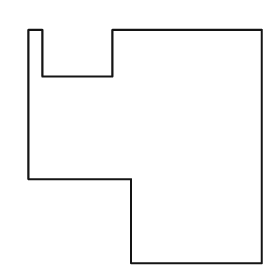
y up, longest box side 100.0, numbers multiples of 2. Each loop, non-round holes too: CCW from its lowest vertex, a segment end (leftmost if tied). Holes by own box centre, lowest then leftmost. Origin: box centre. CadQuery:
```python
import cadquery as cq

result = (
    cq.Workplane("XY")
    .moveTo(-6.0, -50.0)
    .lineTo(50.0, -50.0)
    .lineTo(50.0, 50.0)
    .lineTo(-14.0, 50.0)
    .lineTo(-14.0, 30.0)
    .lineTo(-44.0, 30.0)
    .lineTo(-44.0, 50.0)
    .lineTo(-50.0, 50.0)
    .lineTo(-50.0, -14.0)
    .lineTo(-6.0, -14.0)
    .close()
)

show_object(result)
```